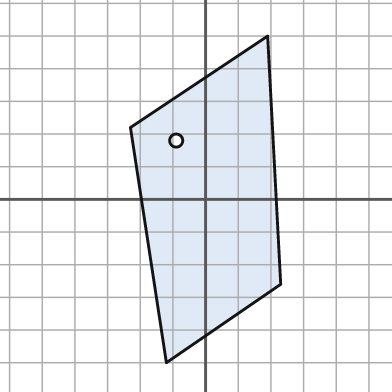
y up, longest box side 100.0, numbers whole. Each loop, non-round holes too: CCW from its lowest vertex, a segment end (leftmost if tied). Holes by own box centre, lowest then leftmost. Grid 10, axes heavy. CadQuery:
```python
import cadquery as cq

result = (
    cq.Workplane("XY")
    .moveTo(-12.0, -50.0)
    .lineTo(23.0, -26.0)
    .lineTo(19.0, 50.0)
    .lineTo(-23.0, 22.0)
    .close()
    .moveTo(-9.0, 18.0)
    .circle(2.0)
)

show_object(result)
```